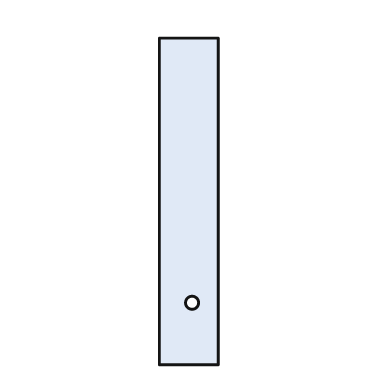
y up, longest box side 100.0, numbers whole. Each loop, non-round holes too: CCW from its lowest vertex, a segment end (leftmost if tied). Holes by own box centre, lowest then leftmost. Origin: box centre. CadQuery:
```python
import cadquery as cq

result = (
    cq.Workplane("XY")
    .moveTo(-9.0, -50.0)
    .lineTo(9.0, -50.0)
    .lineTo(9.0, 50.0)
    .lineTo(-9.0, 50.0)
    .close()
    .moveTo(1.0, -31.0)
    .circle(2.0)
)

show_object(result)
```